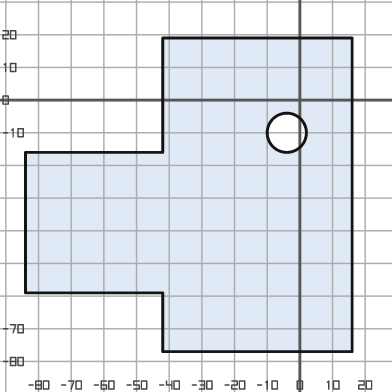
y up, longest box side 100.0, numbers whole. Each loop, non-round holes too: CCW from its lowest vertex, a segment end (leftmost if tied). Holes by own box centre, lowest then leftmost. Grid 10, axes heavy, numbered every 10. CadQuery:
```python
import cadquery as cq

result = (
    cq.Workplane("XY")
    .moveTo(-42.0, -77.0)
    .lineTo(16.0, -77.0)
    .lineTo(16.0, 19.0)
    .lineTo(-42.0, 19.0)
    .lineTo(-42.0, -16.0)
    .lineTo(-84.0, -16.0)
    .lineTo(-84.0, -59.0)
    .lineTo(-42.0, -59.0)
    .close()
    .moveTo(-4.0, -10.0)
    .circle(6.0)
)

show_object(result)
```